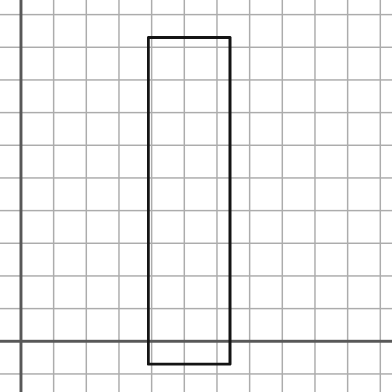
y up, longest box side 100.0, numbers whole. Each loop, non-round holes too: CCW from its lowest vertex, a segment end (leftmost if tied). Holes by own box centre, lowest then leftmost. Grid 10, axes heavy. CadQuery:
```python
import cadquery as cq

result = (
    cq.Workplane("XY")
    .moveTo(39.0, -7.0)
    .lineTo(64.0, -7.0)
    .lineTo(64.0, 93.0)
    .lineTo(39.0, 93.0)
    .close()
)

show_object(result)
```